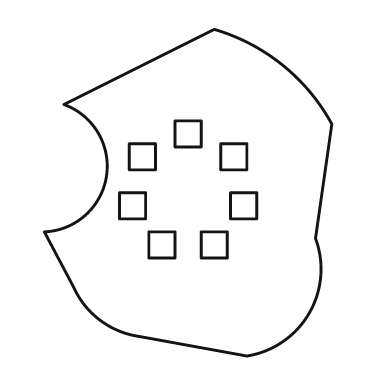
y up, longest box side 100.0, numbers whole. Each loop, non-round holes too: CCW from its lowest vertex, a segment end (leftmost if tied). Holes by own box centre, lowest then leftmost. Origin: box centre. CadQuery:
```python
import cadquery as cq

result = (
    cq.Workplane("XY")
    .moveTo(18.0, -50.0)
    .threePointArc((37.0, -37.0), (39.0, -14.0))
    .lineTo(44.0, 21.0)
    .threePointArc((29.0, 39.0), (8.0, 50.0))
    .lineTo(-38.0, 27.0)
    .threePointArc((-25.0, 5.0), (-44.0, -12.0))
    .lineTo(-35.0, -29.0)
    .threePointArc((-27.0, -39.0), (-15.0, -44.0))
    .close()
    .moveTo(-12.0, -20.0)
    .lineTo(-4.0, -20.0)
    .lineTo(-4.0, -12.0)
    .lineTo(-12.0, -12.0)
    .close()
    .moveTo(4.0, -20.0)
    .lineTo(12.0, -20.0)
    .lineTo(12.0, -12.0)
    .lineTo(4.0, -12.0)
    .close()
    .moveTo(-21.0, -8.0)
    .lineTo(-13.0, -8.0)
    .lineTo(-13.0, 0.0)
    .lineTo(-21.0, 0.0)
    .close()
    .moveTo(13.0, -8.0)
    .lineTo(21.0, -8.0)
    .lineTo(21.0, 0.0)
    .lineTo(13.0, 0.0)
    .close()
    .moveTo(-18.0, 7.0)
    .lineTo(-10.0, 7.0)
    .lineTo(-10.0, 15.0)
    .lineTo(-18.0, 15.0)
    .close()
    .moveTo(10.0, 7.0)
    .lineTo(18.0, 7.0)
    .lineTo(18.0, 15.0)
    .lineTo(10.0, 15.0)
    .close()
    .moveTo(-4.0, 14.0)
    .lineTo(4.0, 14.0)
    .lineTo(4.0, 22.0)
    .lineTo(-4.0, 22.0)
    .close()
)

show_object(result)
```